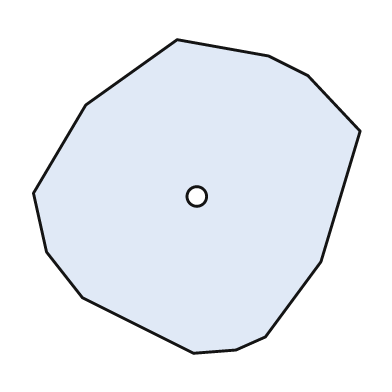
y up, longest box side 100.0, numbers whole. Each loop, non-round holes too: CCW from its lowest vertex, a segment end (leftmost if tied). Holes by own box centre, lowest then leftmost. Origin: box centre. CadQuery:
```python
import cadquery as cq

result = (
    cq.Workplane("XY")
    .moveTo(-1.0, -48.0)
    .lineTo(12.0, -47.0)
    .lineTo(21.0, -43.0)
    .lineTo(38.0, -20.0)
    .lineTo(50.0, 20.0)
    .lineTo(34.0, 37.0)
    .lineTo(22.0, 43.0)
    .lineTo(-6.0, 48.0)
    .lineTo(-34.0, 28.0)
    .lineTo(-50.0, 1.0)
    .lineTo(-46.0, -17.0)
    .lineTo(-35.0, -31.0)
    .close()
    .moveTo(0.0, 0.0)
    .circle(3.0)
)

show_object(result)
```